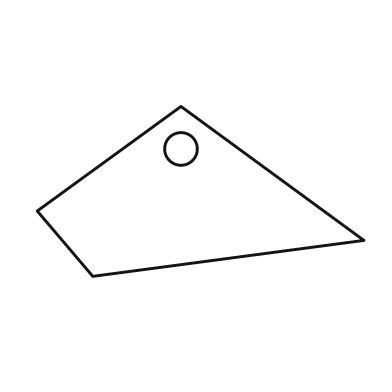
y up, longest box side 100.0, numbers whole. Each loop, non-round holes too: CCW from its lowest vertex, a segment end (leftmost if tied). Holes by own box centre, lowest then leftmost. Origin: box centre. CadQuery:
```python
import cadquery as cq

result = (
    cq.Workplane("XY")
    .moveTo(-33.0, -26.0)
    .lineTo(50.0, -15.0)
    .lineTo(-6.0, 26.0)
    .lineTo(-50.0, -6.0)
    .close()
    .moveTo(-6.0, 13.0)
    .circle(5.0)
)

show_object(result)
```